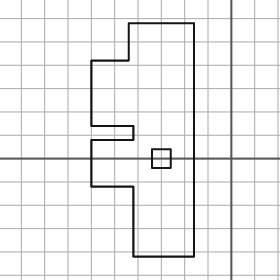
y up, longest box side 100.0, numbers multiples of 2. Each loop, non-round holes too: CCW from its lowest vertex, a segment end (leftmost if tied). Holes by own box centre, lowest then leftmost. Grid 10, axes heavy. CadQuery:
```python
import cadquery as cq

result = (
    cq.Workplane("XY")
    .moveTo(-42.0, -42.0)
    .lineTo(-16.0, -42.0)
    .lineTo(-16.0, 58.0)
    .lineTo(-44.0, 58.0)
    .lineTo(-44.0, 42.0)
    .lineTo(-60.0, 42.0)
    .lineTo(-60.0, 14.0)
    .lineTo(-42.0, 14.0)
    .lineTo(-42.0, 8.0)
    .lineTo(-60.0, 8.0)
    .lineTo(-60.0, -12.0)
    .lineTo(-42.0, -12.0)
    .close()
    .moveTo(-34.0, -4.0)
    .lineTo(-26.0, -4.0)
    .lineTo(-26.0, 4.0)
    .lineTo(-34.0, 4.0)
    .close()
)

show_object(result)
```